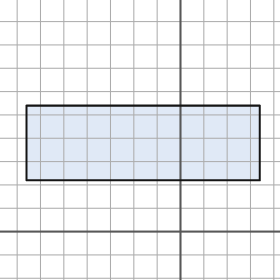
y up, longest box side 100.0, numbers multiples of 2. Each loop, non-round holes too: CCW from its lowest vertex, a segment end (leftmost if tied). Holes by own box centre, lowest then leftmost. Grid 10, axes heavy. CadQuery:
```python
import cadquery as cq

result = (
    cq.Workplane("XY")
    .moveTo(-66.0, 22.0)
    .lineTo(34.0, 22.0)
    .lineTo(34.0, 54.0)
    .lineTo(-66.0, 54.0)
    .close()
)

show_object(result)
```